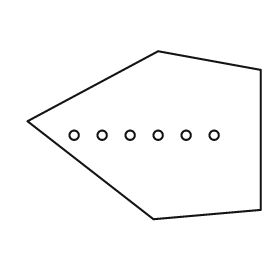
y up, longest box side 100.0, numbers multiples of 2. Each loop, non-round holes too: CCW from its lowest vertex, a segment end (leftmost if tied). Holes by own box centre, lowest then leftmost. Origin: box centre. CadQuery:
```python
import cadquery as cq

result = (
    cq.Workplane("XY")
    .moveTo(4.0, -36.0)
    .lineTo(50.0, -32.0)
    .lineTo(50.0, 28.0)
    .lineTo(6.0, 36.0)
    .lineTo(-50.0, 6.0)
    .close()
    .moveTo(-30.0, 0.0)
    .circle(2.0)
    .moveTo(-18.0, 0.0)
    .circle(2.0)
    .moveTo(-6.0, 0.0)
    .circle(2.0)
    .moveTo(6.0, 0.0)
    .circle(2.0)
    .moveTo(18.0, 0.0)
    .circle(2.0)
    .moveTo(30.0, 0.0)
    .circle(2.0)
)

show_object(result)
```